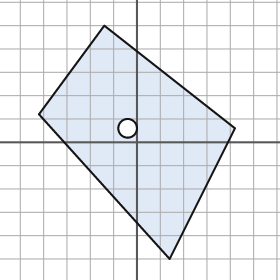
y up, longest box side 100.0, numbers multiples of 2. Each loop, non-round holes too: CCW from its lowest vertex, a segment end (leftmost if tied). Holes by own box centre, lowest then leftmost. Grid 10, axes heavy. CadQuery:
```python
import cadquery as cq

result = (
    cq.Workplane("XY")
    .moveTo(14.0, -50.0)
    .lineTo(42.0, 6.0)
    .lineTo(-14.0, 50.0)
    .lineTo(-42.0, 12.0)
    .close()
    .moveTo(-4.0, 6.0)
    .circle(4.0)
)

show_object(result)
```